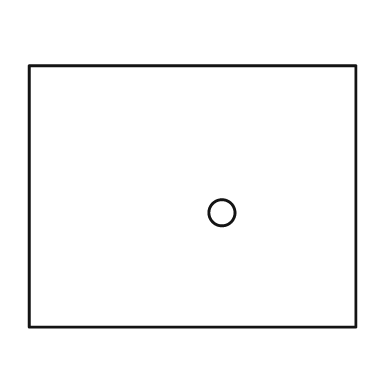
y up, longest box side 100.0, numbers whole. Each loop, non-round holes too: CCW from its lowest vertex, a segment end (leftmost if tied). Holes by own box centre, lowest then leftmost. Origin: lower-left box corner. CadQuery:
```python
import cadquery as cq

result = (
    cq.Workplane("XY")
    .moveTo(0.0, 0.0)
    .lineTo(100.0, 0.0)
    .lineTo(100.0, 80.0)
    .lineTo(0.0, 80.0)
    .close()
    .moveTo(59.0, 35.0)
    .circle(4.0)
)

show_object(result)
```